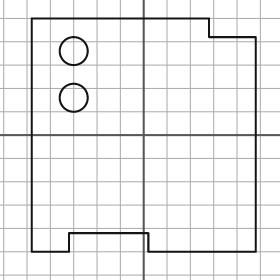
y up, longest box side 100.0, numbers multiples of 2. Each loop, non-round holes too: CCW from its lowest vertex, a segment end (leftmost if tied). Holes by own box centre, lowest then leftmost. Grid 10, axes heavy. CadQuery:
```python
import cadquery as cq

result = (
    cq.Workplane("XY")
    .moveTo(-48.0, -50.0)
    .lineTo(-32.0, -50.0)
    .lineTo(-32.0, -42.0)
    .lineTo(2.0, -42.0)
    .lineTo(2.0, -50.0)
    .lineTo(48.0, -50.0)
    .lineTo(48.0, 42.0)
    .lineTo(28.0, 42.0)
    .lineTo(28.0, 50.0)
    .lineTo(-48.0, 50.0)
    .close()
    .moveTo(-30.0, 16.0)
    .circle(6.0)
    .moveTo(-30.0, 36.0)
    .circle(6.0)
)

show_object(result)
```